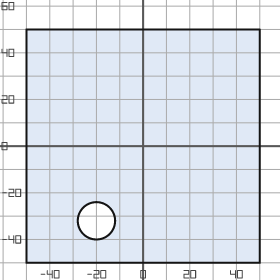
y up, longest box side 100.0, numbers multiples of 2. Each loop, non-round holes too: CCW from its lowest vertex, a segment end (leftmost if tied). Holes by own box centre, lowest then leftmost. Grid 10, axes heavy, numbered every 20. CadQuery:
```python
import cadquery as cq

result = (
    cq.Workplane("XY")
    .moveTo(-50.0, -50.0)
    .lineTo(50.0, -50.0)
    .lineTo(50.0, 50.0)
    .lineTo(-50.0, 50.0)
    .close()
    .moveTo(-20.0, -32.0)
    .circle(8.0)
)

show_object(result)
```